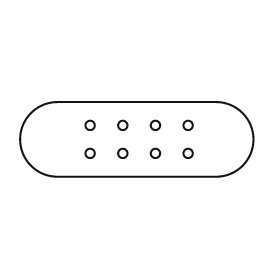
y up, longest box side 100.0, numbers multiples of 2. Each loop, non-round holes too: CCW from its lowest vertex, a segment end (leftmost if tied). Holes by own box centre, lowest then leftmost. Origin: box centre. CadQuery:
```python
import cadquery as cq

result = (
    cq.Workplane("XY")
    .moveTo(-34.0, -16.0)
    .lineTo(34.0, -16.0)
    .threePointArc((50.0, 0.0), (34.0, 16.0))
    .lineTo(-34.0, 16.0)
    .threePointArc((-50.0, 0.0), (-34.0, -16.0))
    .close()
    .moveTo(-20.0, -6.0)
    .circle(2.0)
    .moveTo(-6.0, -6.0)
    .circle(2.0)
    .moveTo(8.0, -6.0)
    .circle(2.0)
    .moveTo(22.0, -6.0)
    .circle(2.0)
    .moveTo(-20.0, 6.0)
    .circle(2.0)
    .moveTo(-6.0, 6.0)
    .circle(2.0)
    .moveTo(8.0, 6.0)
    .circle(2.0)
    .moveTo(22.0, 6.0)
    .circle(2.0)
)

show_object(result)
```